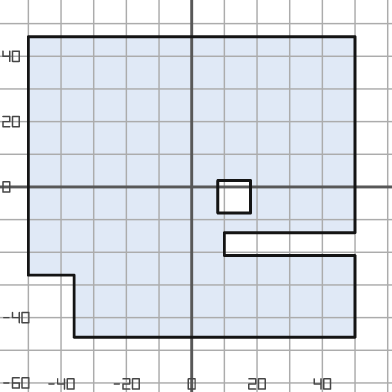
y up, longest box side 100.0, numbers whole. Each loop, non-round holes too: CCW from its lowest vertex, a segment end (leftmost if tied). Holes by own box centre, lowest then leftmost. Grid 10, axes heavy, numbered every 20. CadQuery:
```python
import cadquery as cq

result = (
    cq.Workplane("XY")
    .moveTo(-36.0, -46.0)
    .lineTo(50.0, -46.0)
    .lineTo(50.0, -21.0)
    .lineTo(10.0, -21.0)
    .lineTo(10.0, -14.0)
    .lineTo(50.0, -14.0)
    .lineTo(50.0, 46.0)
    .lineTo(-50.0, 46.0)
    .lineTo(-50.0, -27.0)
    .lineTo(-36.0, -27.0)
    .close()
    .moveTo(8.0, -8.0)
    .lineTo(18.0, -8.0)
    .lineTo(18.0, 2.0)
    .lineTo(8.0, 2.0)
    .close()
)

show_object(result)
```